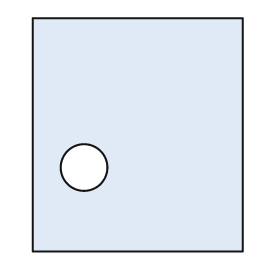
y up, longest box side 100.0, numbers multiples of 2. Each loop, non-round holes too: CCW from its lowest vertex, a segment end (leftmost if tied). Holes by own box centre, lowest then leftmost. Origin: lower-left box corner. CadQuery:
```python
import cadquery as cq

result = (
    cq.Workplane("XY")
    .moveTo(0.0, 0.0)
    .lineTo(90.0, 0.0)
    .lineTo(90.0, 100.0)
    .lineTo(0.0, 100.0)
    .close()
    .moveTo(22.0, 36.0)
    .circle(10.0)
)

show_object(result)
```